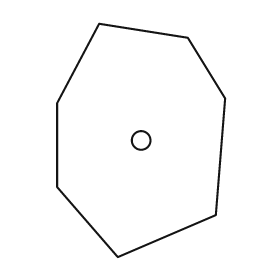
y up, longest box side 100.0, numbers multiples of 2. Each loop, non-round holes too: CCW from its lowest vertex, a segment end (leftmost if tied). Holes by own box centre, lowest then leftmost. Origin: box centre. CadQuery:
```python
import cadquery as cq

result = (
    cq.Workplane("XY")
    .moveTo(-10.0, -50.0)
    .lineTo(32.0, -32.0)
    .lineTo(36.0, 18.0)
    .lineTo(20.0, 44.0)
    .lineTo(-18.0, 50.0)
    .lineTo(-36.0, 16.0)
    .lineTo(-36.0, -20.0)
    .close()
    .moveTo(0.0, 0.0)
    .circle(4.0)
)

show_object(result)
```